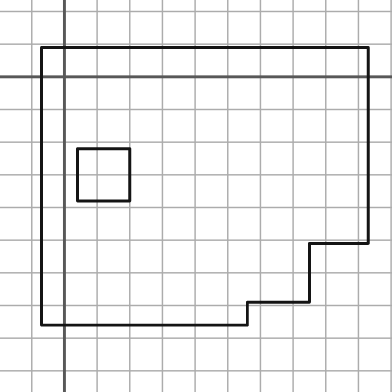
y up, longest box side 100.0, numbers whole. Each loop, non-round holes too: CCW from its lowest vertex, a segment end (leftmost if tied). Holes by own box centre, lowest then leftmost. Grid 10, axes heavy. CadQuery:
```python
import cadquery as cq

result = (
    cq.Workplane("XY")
    .moveTo(-7.0, -76.0)
    .lineTo(56.0, -76.0)
    .lineTo(56.0, -69.0)
    .lineTo(75.0, -69.0)
    .lineTo(75.0, -51.0)
    .lineTo(93.0, -51.0)
    .lineTo(93.0, 9.0)
    .lineTo(-7.0, 9.0)
    .close()
    .moveTo(4.0, -38.0)
    .lineTo(20.0, -38.0)
    .lineTo(20.0, -22.0)
    .lineTo(4.0, -22.0)
    .close()
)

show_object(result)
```